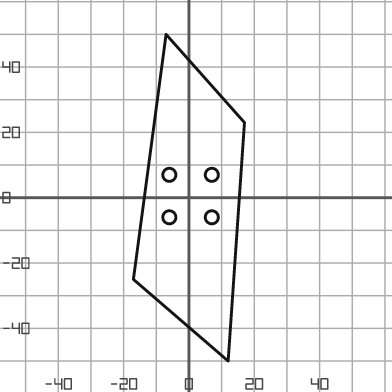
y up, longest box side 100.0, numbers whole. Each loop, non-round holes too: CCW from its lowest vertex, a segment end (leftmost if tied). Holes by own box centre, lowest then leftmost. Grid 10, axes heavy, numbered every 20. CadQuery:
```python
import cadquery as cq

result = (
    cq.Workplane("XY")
    .moveTo(12.0, -50.0)
    .lineTo(17.0, 23.0)
    .lineTo(-7.0, 50.0)
    .lineTo(-17.0, -25.0)
    .close()
    .moveTo(-6.0, -6.0)
    .circle(2.0)
    .moveTo(7.0, -6.0)
    .circle(2.0)
    .moveTo(-6.0, 7.0)
    .circle(2.0)
    .moveTo(7.0, 7.0)
    .circle(2.0)
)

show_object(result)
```